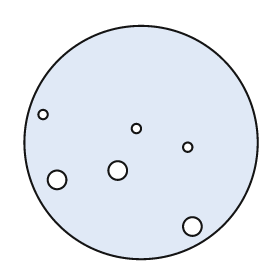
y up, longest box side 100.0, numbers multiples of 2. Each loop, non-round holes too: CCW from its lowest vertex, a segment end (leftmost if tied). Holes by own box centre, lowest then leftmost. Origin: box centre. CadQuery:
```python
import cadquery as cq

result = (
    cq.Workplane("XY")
    .moveTo(0.0, 0.0)
    .circle(50.0)
    .moveTo(22.0, -36.0)
    .circle(4.0)
    .moveTo(-36.0, -16.0)
    .circle(4.0)
    .moveTo(-10.0, -12.0)
    .circle(4.0)
    .moveTo(20.0, -2.0)
    .circle(2.0)
    .moveTo(-2.0, 6.0)
    .circle(2.0)
    .moveTo(-42.0, 12.0)
    .circle(2.0)
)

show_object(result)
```